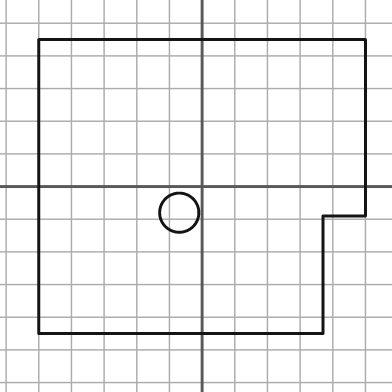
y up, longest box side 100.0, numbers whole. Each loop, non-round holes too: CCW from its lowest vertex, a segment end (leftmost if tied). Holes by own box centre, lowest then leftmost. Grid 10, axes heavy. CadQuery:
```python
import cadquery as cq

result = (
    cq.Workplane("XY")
    .moveTo(-50.0, -45.0)
    .lineTo(37.0, -45.0)
    .lineTo(37.0, -9.0)
    .lineTo(50.0, -9.0)
    .lineTo(50.0, 45.0)
    .lineTo(-50.0, 45.0)
    .close()
    .moveTo(-7.0, -8.0)
    .circle(6.0)
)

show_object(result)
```